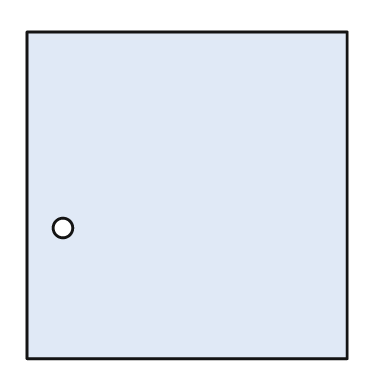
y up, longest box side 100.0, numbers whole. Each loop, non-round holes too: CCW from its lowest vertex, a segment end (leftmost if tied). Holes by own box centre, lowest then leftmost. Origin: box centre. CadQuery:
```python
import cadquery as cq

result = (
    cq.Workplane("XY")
    .moveTo(-49.0, -50.0)
    .lineTo(49.0, -50.0)
    .lineTo(49.0, 50.0)
    .lineTo(-49.0, 50.0)
    .close()
    .moveTo(-38.0, -10.0)
    .circle(3.0)
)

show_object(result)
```